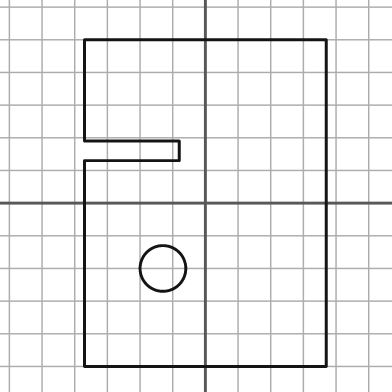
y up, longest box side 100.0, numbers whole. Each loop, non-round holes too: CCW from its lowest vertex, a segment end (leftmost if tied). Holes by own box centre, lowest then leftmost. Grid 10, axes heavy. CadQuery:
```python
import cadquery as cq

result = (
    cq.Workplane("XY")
    .moveTo(-37.0, -50.0)
    .lineTo(37.0, -50.0)
    .lineTo(37.0, 50.0)
    .lineTo(-37.0, 50.0)
    .lineTo(-37.0, 19.0)
    .lineTo(-8.0, 19.0)
    .lineTo(-8.0, 13.0)
    .lineTo(-37.0, 13.0)
    .close()
    .moveTo(-13.0, -20.0)
    .circle(7.0)
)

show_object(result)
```